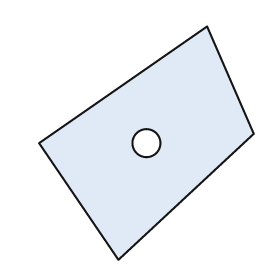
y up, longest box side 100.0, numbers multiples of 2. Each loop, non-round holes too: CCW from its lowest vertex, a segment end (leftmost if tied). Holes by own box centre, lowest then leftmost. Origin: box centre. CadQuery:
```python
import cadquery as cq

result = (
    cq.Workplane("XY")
    .moveTo(-12.0, -50.0)
    .lineTo(46.0, 4.0)
    .lineTo(26.0, 50.0)
    .lineTo(-46.0, 0.0)
    .close()
    .moveTo(0.0, 0.0)
    .circle(6.0)
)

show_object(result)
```